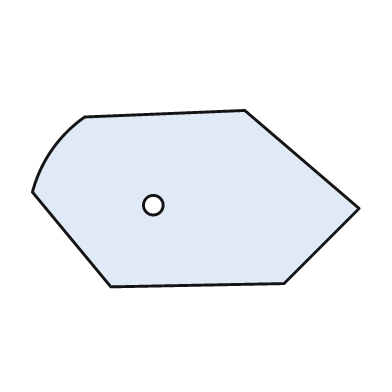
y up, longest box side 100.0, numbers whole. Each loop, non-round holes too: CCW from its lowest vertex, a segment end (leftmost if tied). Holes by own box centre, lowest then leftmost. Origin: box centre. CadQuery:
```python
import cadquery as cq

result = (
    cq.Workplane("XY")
    .moveTo(-26.0, -27.0)
    .lineTo(27.0, -26.0)
    .lineTo(50.0, -3.0)
    .lineTo(15.0, 27.0)
    .lineTo(-34.0, 25.0)
    .threePointArc((-44.0, 15.0), (-50.0, 2.0))
    .close()
    .moveTo(-13.0, -2.0)
    .circle(3.0)
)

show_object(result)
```